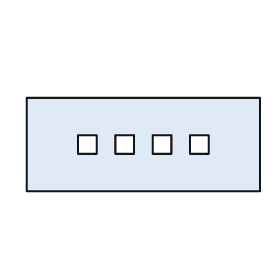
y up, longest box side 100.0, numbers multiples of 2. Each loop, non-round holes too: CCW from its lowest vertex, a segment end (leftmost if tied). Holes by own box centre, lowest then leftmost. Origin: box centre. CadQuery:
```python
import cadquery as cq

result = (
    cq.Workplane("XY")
    .moveTo(-50.0, -20.0)
    .lineTo(50.0, -20.0)
    .lineTo(50.0, 20.0)
    .lineTo(-50.0, 20.0)
    .close()
    .moveTo(-28.0, -4.0)
    .lineTo(-20.0, -4.0)
    .lineTo(-20.0, 4.0)
    .lineTo(-28.0, 4.0)
    .close()
    .moveTo(-12.0, -4.0)
    .lineTo(-4.0, -4.0)
    .lineTo(-4.0, 4.0)
    .lineTo(-12.0, 4.0)
    .close()
    .moveTo(4.0, -4.0)
    .lineTo(12.0, -4.0)
    .lineTo(12.0, 4.0)
    .lineTo(4.0, 4.0)
    .close()
    .moveTo(20.0, -4.0)
    .lineTo(28.0, -4.0)
    .lineTo(28.0, 4.0)
    .lineTo(20.0, 4.0)
    .close()
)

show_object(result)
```